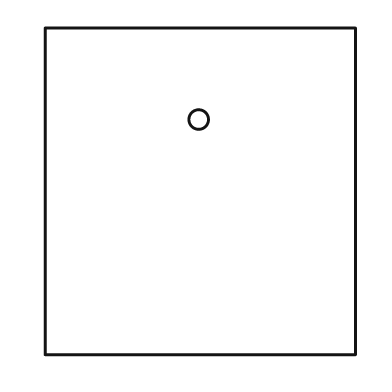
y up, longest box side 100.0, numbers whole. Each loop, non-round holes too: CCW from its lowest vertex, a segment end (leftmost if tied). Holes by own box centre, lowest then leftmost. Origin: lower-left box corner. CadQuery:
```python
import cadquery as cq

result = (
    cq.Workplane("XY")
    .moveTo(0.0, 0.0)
    .lineTo(95.0, 0.0)
    .lineTo(95.0, 100.0)
    .lineTo(0.0, 100.0)
    .close()
    .moveTo(47.0, 72.0)
    .circle(3.0)
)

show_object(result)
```